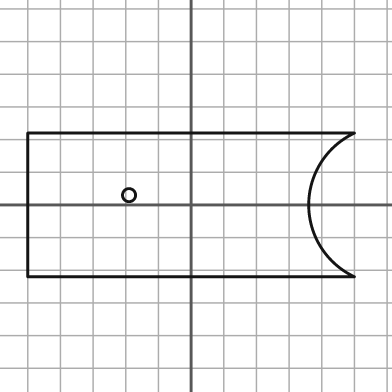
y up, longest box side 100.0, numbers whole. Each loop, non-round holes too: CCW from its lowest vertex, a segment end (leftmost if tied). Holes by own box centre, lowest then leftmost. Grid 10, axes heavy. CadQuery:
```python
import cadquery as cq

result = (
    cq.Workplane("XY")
    .moveTo(-50.0, -22.0)
    .lineTo(50.0, -22.0)
    .threePointArc((36.0, 0.0), (50.0, 22.0))
    .lineTo(-50.0, 22.0)
    .close()
    .moveTo(-19.0, 3.0)
    .circle(2.0)
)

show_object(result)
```